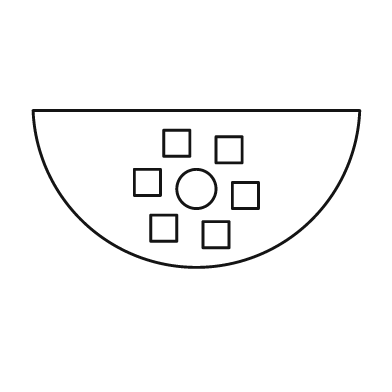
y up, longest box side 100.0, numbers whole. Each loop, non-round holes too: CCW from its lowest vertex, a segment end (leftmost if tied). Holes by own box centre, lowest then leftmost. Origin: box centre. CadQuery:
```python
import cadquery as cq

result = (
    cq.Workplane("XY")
    .moveTo(-50.0, 24.0)
    .threePointArc((0.0, -24.0), (50.0, 24.0))
    .close()
    .moveTo(2.0, -18.0)
    .lineTo(10.0, -18.0)
    .lineTo(10.0, -10.0)
    .lineTo(2.0, -10.0)
    .close()
    .moveTo(-14.0, -16.0)
    .lineTo(-6.0, -16.0)
    .lineTo(-6.0, -8.0)
    .lineTo(-14.0, -8.0)
    .close()
    .moveTo(11.0, -6.0)
    .lineTo(19.0, -6.0)
    .lineTo(19.0, 2.0)
    .lineTo(11.0, 2.0)
    .close()
    .moveTo(0.0, 0.0)
    .circle(6.0)
    .moveTo(-19.0, -2.0)
    .lineTo(-11.0, -2.0)
    .lineTo(-11.0, 6.0)
    .lineTo(-19.0, 6.0)
    .close()
    .moveTo(6.0, 8.0)
    .lineTo(14.0, 8.0)
    .lineTo(14.0, 16.0)
    .lineTo(6.0, 16.0)
    .close()
    .moveTo(-10.0, 10.0)
    .lineTo(-2.0, 10.0)
    .lineTo(-2.0, 18.0)
    .lineTo(-10.0, 18.0)
    .close()
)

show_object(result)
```